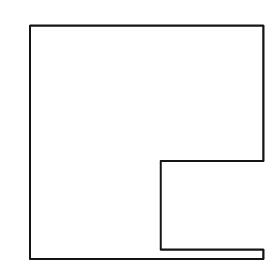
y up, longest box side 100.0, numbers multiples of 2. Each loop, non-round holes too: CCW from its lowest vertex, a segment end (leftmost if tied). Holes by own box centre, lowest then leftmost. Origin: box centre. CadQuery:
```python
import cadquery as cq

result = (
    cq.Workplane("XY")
    .moveTo(-50.0, -50.0)
    .lineTo(50.0, -50.0)
    .lineTo(50.0, -46.0)
    .lineTo(6.0, -46.0)
    .lineTo(6.0, -8.0)
    .lineTo(50.0, -8.0)
    .lineTo(50.0, 50.0)
    .lineTo(-50.0, 50.0)
    .close()
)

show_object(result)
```